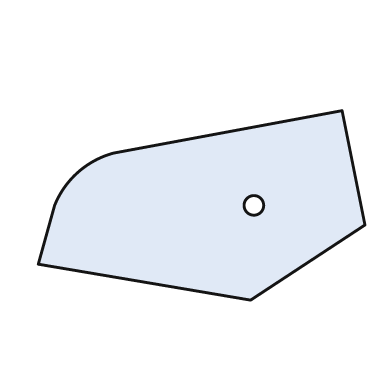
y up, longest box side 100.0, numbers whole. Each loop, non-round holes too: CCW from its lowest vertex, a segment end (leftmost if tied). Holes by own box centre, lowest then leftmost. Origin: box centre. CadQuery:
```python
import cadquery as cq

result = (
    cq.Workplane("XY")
    .moveTo(15.0, -29.0)
    .lineTo(50.0, -6.0)
    .lineTo(43.0, 29.0)
    .lineTo(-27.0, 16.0)
    .threePointArc((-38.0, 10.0), (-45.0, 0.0))
    .lineTo(-50.0, -18.0)
    .close()
    .moveTo(16.0, 0.0)
    .circle(3.0)
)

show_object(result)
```